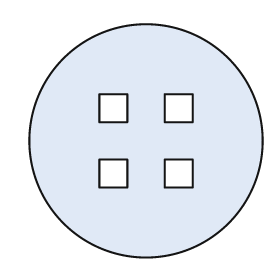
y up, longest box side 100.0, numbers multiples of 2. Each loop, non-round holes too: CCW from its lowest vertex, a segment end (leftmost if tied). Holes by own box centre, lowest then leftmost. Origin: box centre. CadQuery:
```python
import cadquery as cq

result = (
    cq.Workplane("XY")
    .moveTo(0.0, 0.0)
    .circle(50.0)
    .moveTo(-20.0, -20.0)
    .lineTo(-8.0, -20.0)
    .lineTo(-8.0, -8.0)
    .lineTo(-20.0, -8.0)
    .close()
    .moveTo(8.0, -20.0)
    .lineTo(20.0, -20.0)
    .lineTo(20.0, -8.0)
    .lineTo(8.0, -8.0)
    .close()
    .moveTo(-20.0, 8.0)
    .lineTo(-8.0, 8.0)
    .lineTo(-8.0, 20.0)
    .lineTo(-20.0, 20.0)
    .close()
    .moveTo(8.0, 8.0)
    .lineTo(20.0, 8.0)
    .lineTo(20.0, 20.0)
    .lineTo(8.0, 20.0)
    .close()
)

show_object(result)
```